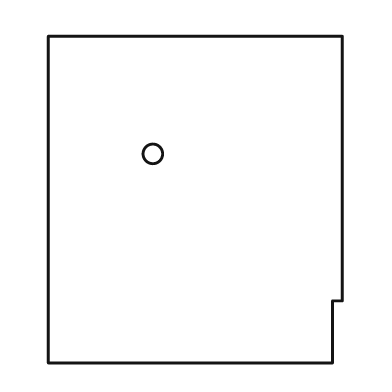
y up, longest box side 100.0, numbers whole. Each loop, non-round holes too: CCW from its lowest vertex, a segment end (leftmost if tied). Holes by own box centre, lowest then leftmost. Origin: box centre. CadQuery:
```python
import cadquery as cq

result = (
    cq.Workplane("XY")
    .moveTo(-45.0, -50.0)
    .lineTo(42.0, -50.0)
    .lineTo(42.0, -31.0)
    .lineTo(45.0, -31.0)
    .lineTo(45.0, 50.0)
    .lineTo(-45.0, 50.0)
    .close()
    .moveTo(-13.0, 14.0)
    .circle(3.0)
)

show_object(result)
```